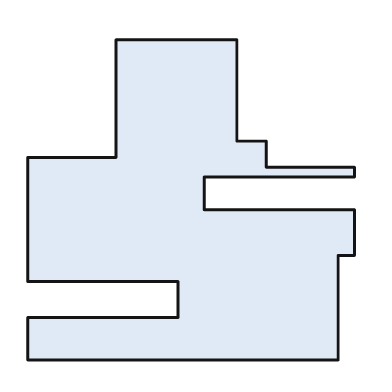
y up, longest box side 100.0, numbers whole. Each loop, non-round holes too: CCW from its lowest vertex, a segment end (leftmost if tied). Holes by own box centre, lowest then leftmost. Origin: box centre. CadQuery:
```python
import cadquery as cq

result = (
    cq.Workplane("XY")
    .moveTo(-50.0, -49.0)
    .lineTo(45.0, -49.0)
    .lineTo(45.0, -17.0)
    .lineTo(50.0, -17.0)
    .lineTo(50.0, -3.0)
    .lineTo(4.0, -3.0)
    .lineTo(4.0, 7.0)
    .lineTo(50.0, 7.0)
    .lineTo(50.0, 10.0)
    .lineTo(23.0, 10.0)
    .lineTo(23.0, 18.0)
    .lineTo(14.0, 18.0)
    .lineTo(14.0, 49.0)
    .lineTo(-23.0, 49.0)
    .lineTo(-23.0, 13.0)
    .lineTo(-50.0, 13.0)
    .lineTo(-50.0, -25.0)
    .lineTo(-4.0, -25.0)
    .lineTo(-4.0, -36.0)
    .lineTo(-50.0, -36.0)
    .close()
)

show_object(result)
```